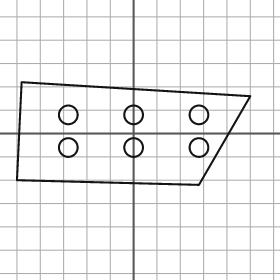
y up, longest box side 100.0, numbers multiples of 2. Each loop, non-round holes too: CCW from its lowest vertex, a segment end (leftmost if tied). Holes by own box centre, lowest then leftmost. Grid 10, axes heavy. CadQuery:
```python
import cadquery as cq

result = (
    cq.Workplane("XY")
    .moveTo(28.0, -22.0)
    .lineTo(50.0, 16.0)
    .lineTo(-48.0, 22.0)
    .lineTo(-50.0, -20.0)
    .close()
    .moveTo(-28.0, -6.0)
    .circle(4.0)
    .moveTo(0.0, -6.0)
    .circle(4.0)
    .moveTo(28.0, -6.0)
    .circle(4.0)
    .moveTo(-28.0, 8.0)
    .circle(4.0)
    .moveTo(0.0, 8.0)
    .circle(4.0)
    .moveTo(28.0, 8.0)
    .circle(4.0)
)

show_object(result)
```